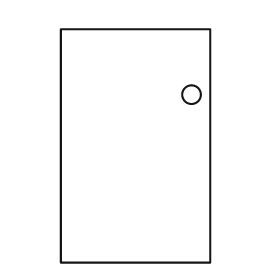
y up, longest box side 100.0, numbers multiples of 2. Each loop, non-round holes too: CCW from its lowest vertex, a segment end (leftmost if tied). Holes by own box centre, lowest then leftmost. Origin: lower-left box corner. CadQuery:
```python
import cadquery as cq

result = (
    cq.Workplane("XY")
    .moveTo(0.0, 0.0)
    .lineTo(64.0, 0.0)
    .lineTo(64.0, 100.0)
    .lineTo(0.0, 100.0)
    .close()
    .moveTo(56.0, 72.0)
    .circle(4.0)
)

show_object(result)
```